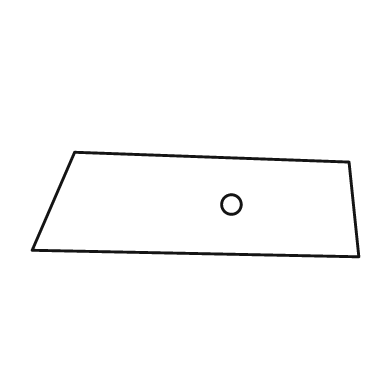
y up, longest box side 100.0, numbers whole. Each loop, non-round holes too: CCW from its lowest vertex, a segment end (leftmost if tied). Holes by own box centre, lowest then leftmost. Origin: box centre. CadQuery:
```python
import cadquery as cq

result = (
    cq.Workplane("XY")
    .moveTo(50.0, -16.0)
    .lineTo(47.0, 13.0)
    .lineTo(-37.0, 16.0)
    .lineTo(-50.0, -14.0)
    .close()
    .moveTo(11.0, 0.0)
    .circle(3.0)
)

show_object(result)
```